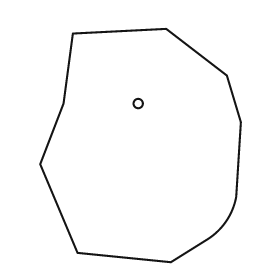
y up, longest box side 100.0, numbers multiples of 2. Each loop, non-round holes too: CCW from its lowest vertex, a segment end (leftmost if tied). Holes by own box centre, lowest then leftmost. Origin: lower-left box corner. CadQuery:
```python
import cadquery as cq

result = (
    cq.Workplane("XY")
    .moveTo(56.0, 0.0)
    .lineTo(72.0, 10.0)
    .threePointArc((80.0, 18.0), (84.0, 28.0))
    .lineTo(86.0, 60.0)
    .lineTo(80.0, 80.0)
    .lineTo(54.0, 100.0)
    .lineTo(14.0, 98.0)
    .lineTo(10.0, 68.0)
    .lineTo(0.0, 42.0)
    .lineTo(16.0, 4.0)
    .close()
    .moveTo(42.0, 68.0)
    .circle(2.0)
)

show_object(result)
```